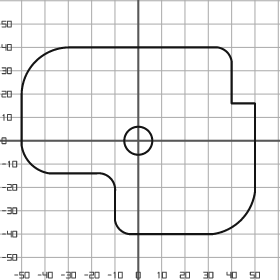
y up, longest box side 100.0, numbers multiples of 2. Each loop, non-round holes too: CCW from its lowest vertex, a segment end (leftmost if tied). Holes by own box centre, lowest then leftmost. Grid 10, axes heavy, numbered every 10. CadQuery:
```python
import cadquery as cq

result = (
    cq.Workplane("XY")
    .moveTo(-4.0, -40.0)
    .lineTo(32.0, -40.0)
    .threePointArc((44.0, -34.0), (50.0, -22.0))
    .lineTo(50.0, 16.0)
    .lineTo(40.0, 16.0)
    .lineTo(40.0, 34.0)
    .threePointArc((38.0, 38.0), (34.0, 40.0))
    .lineTo(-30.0, 40.0)
    .threePointArc((-44.0, 34.0), (-50.0, 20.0))
    .lineTo(-50.0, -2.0)
    .threePointArc((-46.0, -10.0), (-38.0, -14.0))
    .lineTo(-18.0, -14.0)
    .threePointArc((-12.0, -16.0), (-10.0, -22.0))
    .lineTo(-10.0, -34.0)
    .threePointArc((-8.0, -38.0), (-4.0, -40.0))
    .close()
    .moveTo(0.0, 0.0)
    .circle(6.0)
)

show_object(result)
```